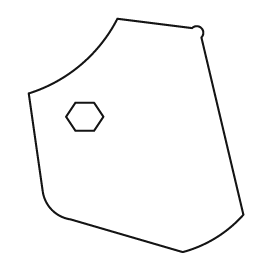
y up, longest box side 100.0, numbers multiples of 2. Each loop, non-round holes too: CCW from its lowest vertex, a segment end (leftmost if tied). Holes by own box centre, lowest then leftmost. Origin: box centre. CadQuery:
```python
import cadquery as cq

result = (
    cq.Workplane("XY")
    .moveTo(20.0, -50.0)
    .threePointArc((34.0, -44.0), (46.0, -34.0))
    .lineTo(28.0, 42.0)
    .threePointArc((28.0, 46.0), (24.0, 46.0))
    .lineTo(-8.0, 50.0)
    .threePointArc((-24.0, 30.0), (-46.0, 18.0))
    .lineTo(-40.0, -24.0)
    .threePointArc((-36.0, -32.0), (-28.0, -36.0))
    .close()
    .moveTo(-26.0, 2.0)
    .lineTo(-18.0, 2.0)
    .lineTo(-14.0, 8.0)
    .lineTo(-18.0, 14.0)
    .lineTo(-26.0, 14.0)
    .lineTo(-30.0, 8.0)
    .close()
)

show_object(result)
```